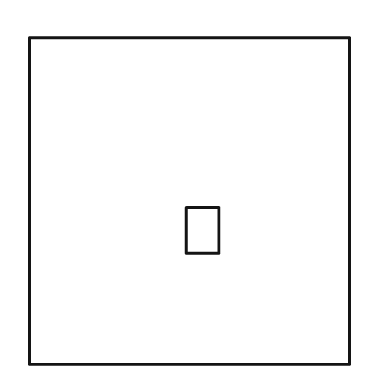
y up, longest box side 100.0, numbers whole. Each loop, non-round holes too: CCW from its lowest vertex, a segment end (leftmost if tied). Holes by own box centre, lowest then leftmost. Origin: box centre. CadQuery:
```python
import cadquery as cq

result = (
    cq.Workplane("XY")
    .moveTo(-49.0, -50.0)
    .lineTo(49.0, -50.0)
    .lineTo(49.0, 50.0)
    .lineTo(-49.0, 50.0)
    .close()
    .moveTo(-1.0, -16.0)
    .lineTo(9.0, -16.0)
    .lineTo(9.0, -2.0)
    .lineTo(-1.0, -2.0)
    .close()
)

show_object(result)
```